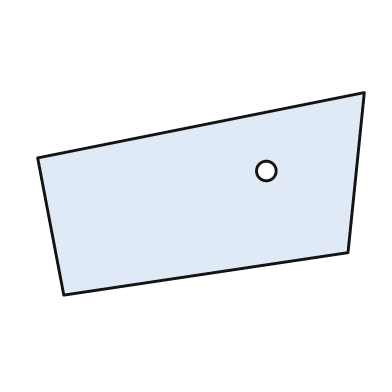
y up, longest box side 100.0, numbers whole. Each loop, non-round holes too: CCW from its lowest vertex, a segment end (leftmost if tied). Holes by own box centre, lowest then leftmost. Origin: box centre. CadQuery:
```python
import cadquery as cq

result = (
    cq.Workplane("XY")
    .moveTo(-42.0, -31.0)
    .lineTo(45.0, -18.0)
    .lineTo(50.0, 31.0)
    .lineTo(-50.0, 11.0)
    .close()
    .moveTo(20.0, 7.0)
    .circle(3.0)
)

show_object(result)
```